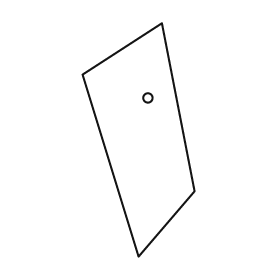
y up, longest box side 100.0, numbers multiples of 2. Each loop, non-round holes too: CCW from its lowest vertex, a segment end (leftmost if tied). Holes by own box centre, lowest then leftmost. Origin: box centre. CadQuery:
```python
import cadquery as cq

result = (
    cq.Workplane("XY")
    .moveTo(0.0, -50.0)
    .lineTo(24.0, -22.0)
    .lineTo(10.0, 50.0)
    .lineTo(-24.0, 28.0)
    .close()
    .moveTo(4.0, 18.0)
    .circle(2.0)
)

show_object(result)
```